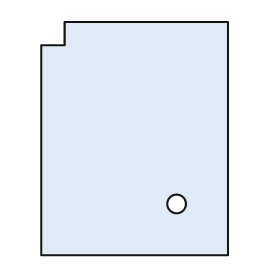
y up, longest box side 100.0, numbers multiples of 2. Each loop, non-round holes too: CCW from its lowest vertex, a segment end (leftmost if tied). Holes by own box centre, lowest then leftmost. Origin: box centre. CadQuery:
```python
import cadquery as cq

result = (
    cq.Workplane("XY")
    .moveTo(-40.0, -50.0)
    .lineTo(40.0, -50.0)
    .lineTo(40.0, 50.0)
    .lineTo(-30.0, 50.0)
    .lineTo(-30.0, 40.0)
    .lineTo(-40.0, 40.0)
    .close()
    .moveTo(18.0, -28.0)
    .circle(4.0)
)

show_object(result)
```